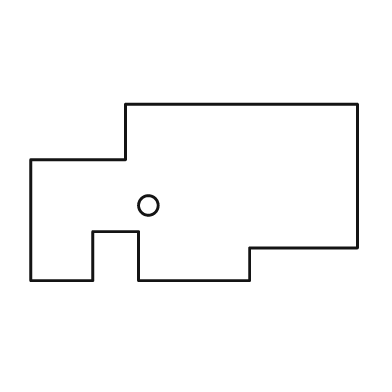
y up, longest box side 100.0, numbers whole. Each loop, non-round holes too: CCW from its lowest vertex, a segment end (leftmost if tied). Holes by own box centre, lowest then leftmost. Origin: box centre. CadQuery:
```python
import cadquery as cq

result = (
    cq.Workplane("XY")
    .moveTo(-50.0, -27.0)
    .lineTo(-31.0, -27.0)
    .lineTo(-31.0, -12.0)
    .lineTo(-17.0, -12.0)
    .lineTo(-17.0, -27.0)
    .lineTo(17.0, -27.0)
    .lineTo(17.0, -17.0)
    .lineTo(50.0, -17.0)
    .lineTo(50.0, 27.0)
    .lineTo(-21.0, 27.0)
    .lineTo(-21.0, 10.0)
    .lineTo(-50.0, 10.0)
    .close()
    .moveTo(-14.0, -4.0)
    .circle(3.0)
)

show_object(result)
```